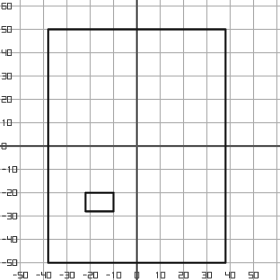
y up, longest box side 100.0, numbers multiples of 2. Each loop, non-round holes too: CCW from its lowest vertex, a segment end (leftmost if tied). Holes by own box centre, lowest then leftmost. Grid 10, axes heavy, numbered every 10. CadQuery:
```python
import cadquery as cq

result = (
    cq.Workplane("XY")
    .moveTo(-38.0, -50.0)
    .lineTo(38.0, -50.0)
    .lineTo(38.0, 50.0)
    .lineTo(-38.0, 50.0)
    .close()
    .moveTo(-22.0, -28.0)
    .lineTo(-10.0, -28.0)
    .lineTo(-10.0, -20.0)
    .lineTo(-22.0, -20.0)
    .close()
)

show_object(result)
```